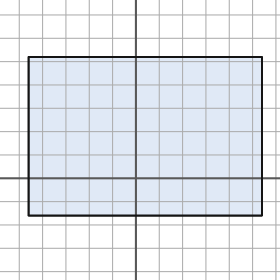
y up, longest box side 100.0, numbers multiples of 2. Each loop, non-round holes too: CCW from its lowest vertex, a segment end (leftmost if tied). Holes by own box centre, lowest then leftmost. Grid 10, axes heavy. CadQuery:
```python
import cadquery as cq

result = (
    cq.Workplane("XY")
    .moveTo(-46.0, -16.0)
    .lineTo(54.0, -16.0)
    .lineTo(54.0, 52.0)
    .lineTo(-46.0, 52.0)
    .close()
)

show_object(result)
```